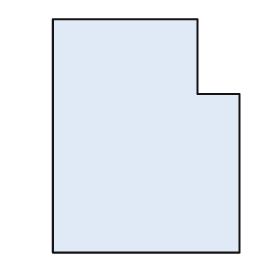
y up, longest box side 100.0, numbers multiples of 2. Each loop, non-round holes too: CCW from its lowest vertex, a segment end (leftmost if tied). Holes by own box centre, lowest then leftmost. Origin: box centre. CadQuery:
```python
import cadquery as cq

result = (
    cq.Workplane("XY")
    .moveTo(-40.0, -50.0)
    .lineTo(40.0, -50.0)
    .lineTo(40.0, 18.0)
    .lineTo(22.0, 18.0)
    .lineTo(22.0, 50.0)
    .lineTo(-40.0, 50.0)
    .close()
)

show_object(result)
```